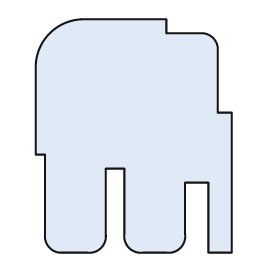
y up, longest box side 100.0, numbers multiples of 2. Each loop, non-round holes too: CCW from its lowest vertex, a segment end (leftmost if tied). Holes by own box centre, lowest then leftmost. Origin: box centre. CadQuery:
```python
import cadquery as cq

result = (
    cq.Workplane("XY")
    .moveTo(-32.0, -50.0)
    .lineTo(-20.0, -50.0)
    .threePointArc((-14.0, -48.0), (-12.0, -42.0))
    .lineTo(-12.0, -14.0)
    .lineTo(-4.0, -14.0)
    .lineTo(-4.0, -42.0)
    .threePointArc((-2.0, -48.0), (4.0, -50.0))
    .lineTo(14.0, -50.0)
    .threePointArc((20.0, -48.0), (22.0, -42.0))
    .lineTo(22.0, -20.0)
    .lineTo(32.0, -20.0)
    .lineTo(32.0, -50.0)
    .lineTo(42.0, -50.0)
    .lineTo(42.0, 10.0)
    .lineTo(36.0, 10.0)
    .lineTo(36.0, 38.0)
    .threePointArc((34.0, 42.0), (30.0, 44.0))
    .lineTo(14.0, 44.0)
    .lineTo(14.0, 50.0)
    .lineTo(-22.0, 50.0)
    .threePointArc((-36.0, 44.0), (-42.0, 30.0))
    .lineTo(-42.0, -8.0)
    .lineTo(-38.0, -8.0)
    .lineTo(-38.0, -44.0)
    .threePointArc((-36.0, -48.0), (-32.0, -50.0))
    .close()
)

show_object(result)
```